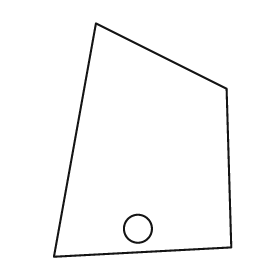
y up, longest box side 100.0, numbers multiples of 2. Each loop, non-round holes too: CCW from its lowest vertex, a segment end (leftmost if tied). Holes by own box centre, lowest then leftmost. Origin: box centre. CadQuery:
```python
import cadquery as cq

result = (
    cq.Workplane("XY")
    .moveTo(-38.0, -50.0)
    .lineTo(38.0, -46.0)
    .lineTo(36.0, 22.0)
    .lineTo(-20.0, 50.0)
    .close()
    .moveTo(-2.0, -38.0)
    .circle(6.0)
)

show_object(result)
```